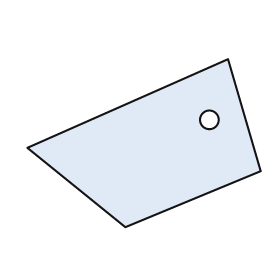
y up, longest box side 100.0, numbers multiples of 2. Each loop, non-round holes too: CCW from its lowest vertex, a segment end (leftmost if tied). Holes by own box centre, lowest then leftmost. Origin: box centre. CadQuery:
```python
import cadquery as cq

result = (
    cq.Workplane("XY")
    .moveTo(-8.0, -36.0)
    .lineTo(50.0, -12.0)
    .lineTo(36.0, 36.0)
    .lineTo(-50.0, -2.0)
    .close()
    .moveTo(28.0, 10.0)
    .circle(4.0)
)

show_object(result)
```